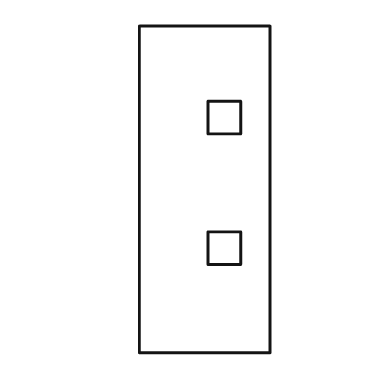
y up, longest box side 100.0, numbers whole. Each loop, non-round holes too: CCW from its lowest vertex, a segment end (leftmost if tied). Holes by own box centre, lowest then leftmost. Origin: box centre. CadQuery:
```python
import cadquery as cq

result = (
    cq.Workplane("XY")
    .moveTo(-20.0, -50.0)
    .lineTo(20.0, -50.0)
    .lineTo(20.0, 50.0)
    .lineTo(-20.0, 50.0)
    .close()
    .moveTo(1.0, -23.0)
    .lineTo(11.0, -23.0)
    .lineTo(11.0, -13.0)
    .lineTo(1.0, -13.0)
    .close()
    .moveTo(1.0, 17.0)
    .lineTo(11.0, 17.0)
    .lineTo(11.0, 27.0)
    .lineTo(1.0, 27.0)
    .close()
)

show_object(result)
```